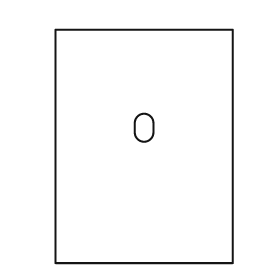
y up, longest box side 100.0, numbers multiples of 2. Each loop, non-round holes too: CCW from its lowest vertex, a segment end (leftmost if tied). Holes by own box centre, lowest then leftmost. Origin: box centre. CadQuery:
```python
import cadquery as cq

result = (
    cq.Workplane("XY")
    .moveTo(-38.0, -50.0)
    .lineTo(38.0, -50.0)
    .lineTo(38.0, 50.0)
    .lineTo(-38.0, 50.0)
    .close()
    .moveTo(-4.0, 6.0)
    .threePointArc((0.0, 2.0), (4.0, 6.0))
    .lineTo(4.0, 10.0)
    .threePointArc((0.0, 14.0), (-4.0, 10.0))
    .close()
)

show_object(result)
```